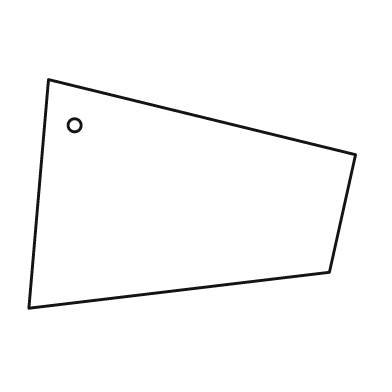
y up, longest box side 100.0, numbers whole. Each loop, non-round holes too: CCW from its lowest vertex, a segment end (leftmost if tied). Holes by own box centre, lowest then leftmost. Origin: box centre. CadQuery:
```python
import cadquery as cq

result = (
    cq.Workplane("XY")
    .moveTo(-50.0, -35.0)
    .lineTo(42.0, -24.0)
    .lineTo(50.0, 12.0)
    .lineTo(-44.0, 35.0)
    .close()
    .moveTo(-36.0, 21.0)
    .circle(2.0)
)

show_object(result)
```